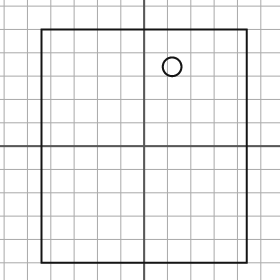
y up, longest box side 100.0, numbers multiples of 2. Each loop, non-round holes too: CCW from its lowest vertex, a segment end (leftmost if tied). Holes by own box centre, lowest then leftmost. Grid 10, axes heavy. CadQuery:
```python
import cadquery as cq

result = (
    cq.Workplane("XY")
    .moveTo(-44.0, -50.0)
    .lineTo(44.0, -50.0)
    .lineTo(44.0, 50.0)
    .lineTo(-44.0, 50.0)
    .close()
    .moveTo(12.0, 34.0)
    .circle(4.0)
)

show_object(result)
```